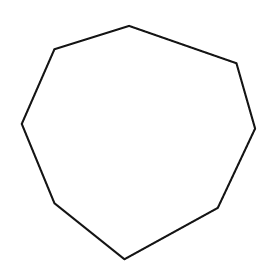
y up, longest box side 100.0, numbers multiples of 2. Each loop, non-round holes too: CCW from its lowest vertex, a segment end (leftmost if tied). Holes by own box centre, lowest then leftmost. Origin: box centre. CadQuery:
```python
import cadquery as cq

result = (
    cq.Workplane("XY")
    .moveTo(-6.0, -50.0)
    .lineTo(34.0, -28.0)
    .lineTo(50.0, 6.0)
    .lineTo(42.0, 34.0)
    .lineTo(-4.0, 50.0)
    .lineTo(-36.0, 40.0)
    .lineTo(-50.0, 8.0)
    .lineTo(-36.0, -26.0)
    .close()
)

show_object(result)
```